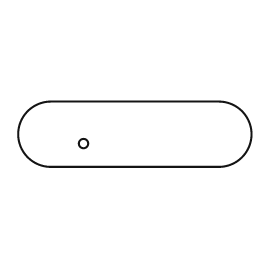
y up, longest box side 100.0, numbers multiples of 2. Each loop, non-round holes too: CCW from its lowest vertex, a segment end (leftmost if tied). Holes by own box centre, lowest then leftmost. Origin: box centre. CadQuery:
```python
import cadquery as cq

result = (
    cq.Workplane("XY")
    .moveTo(-36.0, -14.0)
    .lineTo(36.0, -14.0)
    .threePointArc((50.0, 0.0), (36.0, 14.0))
    .lineTo(-36.0, 14.0)
    .threePointArc((-50.0, 0.0), (-36.0, -14.0))
    .close()
    .moveTo(-22.0, -4.0)
    .circle(2.0)
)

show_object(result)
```